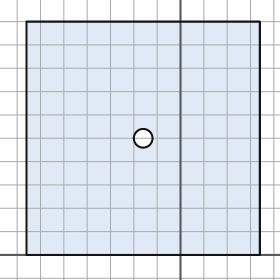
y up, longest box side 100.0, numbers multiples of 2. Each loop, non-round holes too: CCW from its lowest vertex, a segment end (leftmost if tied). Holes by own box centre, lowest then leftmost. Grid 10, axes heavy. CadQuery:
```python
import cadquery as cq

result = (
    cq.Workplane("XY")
    .moveTo(-66.0, 0.0)
    .lineTo(34.0, 0.0)
    .lineTo(34.0, 100.0)
    .lineTo(-66.0, 100.0)
    .close()
    .moveTo(-16.0, 50.0)
    .circle(4.0)
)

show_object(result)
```